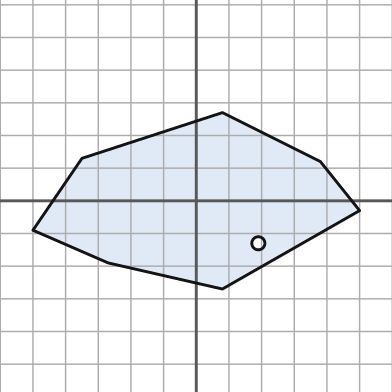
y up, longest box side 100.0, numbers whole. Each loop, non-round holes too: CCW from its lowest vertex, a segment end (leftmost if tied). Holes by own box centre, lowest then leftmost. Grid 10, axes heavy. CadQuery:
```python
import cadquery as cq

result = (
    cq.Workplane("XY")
    .moveTo(8.0, -27.0)
    .lineTo(50.0, -3.0)
    .lineTo(38.0, 12.0)
    .lineTo(8.0, 27.0)
    .lineTo(-35.0, 13.0)
    .lineTo(-50.0, -9.0)
    .lineTo(-27.0, -19.0)
    .close()
    .moveTo(19.0, -13.0)
    .circle(2.0)
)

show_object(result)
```